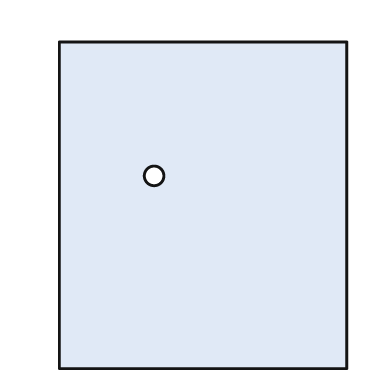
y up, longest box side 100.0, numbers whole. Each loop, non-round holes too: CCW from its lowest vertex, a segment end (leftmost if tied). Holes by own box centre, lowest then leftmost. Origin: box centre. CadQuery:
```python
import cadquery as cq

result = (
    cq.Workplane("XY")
    .moveTo(-44.0, -50.0)
    .lineTo(44.0, -50.0)
    .lineTo(44.0, 50.0)
    .lineTo(-44.0, 50.0)
    .close()
    .moveTo(-15.0, 9.0)
    .circle(3.0)
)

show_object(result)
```